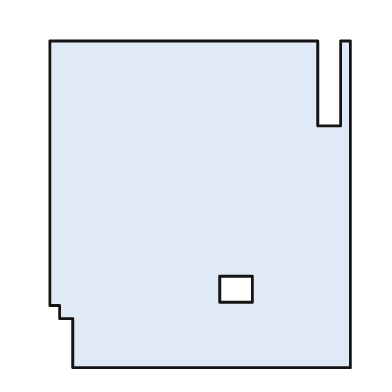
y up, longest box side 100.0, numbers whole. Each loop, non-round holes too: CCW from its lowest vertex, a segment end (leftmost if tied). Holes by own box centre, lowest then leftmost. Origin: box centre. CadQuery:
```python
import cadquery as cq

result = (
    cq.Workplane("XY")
    .moveTo(-39.0, -50.0)
    .lineTo(46.0, -50.0)
    .lineTo(46.0, 50.0)
    .lineTo(43.0, 50.0)
    .lineTo(43.0, 24.0)
    .lineTo(36.0, 24.0)
    .lineTo(36.0, 50.0)
    .lineTo(-46.0, 50.0)
    .lineTo(-46.0, -31.0)
    .lineTo(-43.0, -31.0)
    .lineTo(-43.0, -35.0)
    .lineTo(-39.0, -35.0)
    .close()
    .moveTo(6.0, -30.0)
    .lineTo(16.0, -30.0)
    .lineTo(16.0, -22.0)
    .lineTo(6.0, -22.0)
    .close()
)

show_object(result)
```